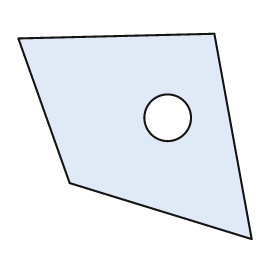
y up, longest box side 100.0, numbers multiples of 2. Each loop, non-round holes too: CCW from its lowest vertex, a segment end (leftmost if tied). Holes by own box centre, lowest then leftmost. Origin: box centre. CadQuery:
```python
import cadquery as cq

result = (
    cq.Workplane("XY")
    .moveTo(50.0, -44.0)
    .lineTo(34.0, 44.0)
    .lineTo(-50.0, 42.0)
    .lineTo(-28.0, -20.0)
    .close()
    .moveTo(14.0, 8.0)
    .circle(10.0)
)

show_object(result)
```